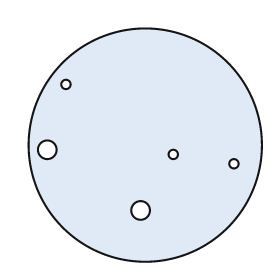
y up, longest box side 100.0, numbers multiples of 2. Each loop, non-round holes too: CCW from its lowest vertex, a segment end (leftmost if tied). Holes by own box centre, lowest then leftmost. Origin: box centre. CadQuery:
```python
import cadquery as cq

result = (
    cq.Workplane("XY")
    .moveTo(0.0, 0.0)
    .circle(50.0)
    .moveTo(-2.0, -28.0)
    .circle(4.0)
    .moveTo(38.0, -8.0)
    .circle(2.0)
    .moveTo(12.0, -4.0)
    .circle(2.0)
    .moveTo(-42.0, -2.0)
    .circle(4.0)
    .moveTo(-34.0, 26.0)
    .circle(2.0)
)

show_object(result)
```